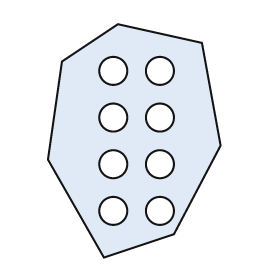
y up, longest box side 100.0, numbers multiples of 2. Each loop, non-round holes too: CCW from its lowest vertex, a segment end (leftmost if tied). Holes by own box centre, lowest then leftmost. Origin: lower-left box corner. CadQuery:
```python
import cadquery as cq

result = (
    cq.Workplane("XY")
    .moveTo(24.0, 0.0)
    .lineTo(54.0, 10.0)
    .lineTo(74.0, 48.0)
    .lineTo(66.0, 92.0)
    .lineTo(30.0, 100.0)
    .lineTo(6.0, 84.0)
    .lineTo(0.0, 42.0)
    .close()
    .moveTo(28.0, 20.0)
    .circle(6.0)
    .moveTo(48.0, 20.0)
    .circle(6.0)
    .moveTo(28.0, 40.0)
    .circle(6.0)
    .moveTo(48.0, 40.0)
    .circle(6.0)
    .moveTo(28.0, 60.0)
    .circle(6.0)
    .moveTo(48.0, 60.0)
    .circle(6.0)
    .moveTo(28.0, 80.0)
    .circle(6.0)
    .moveTo(48.0, 80.0)
    .circle(6.0)
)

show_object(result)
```